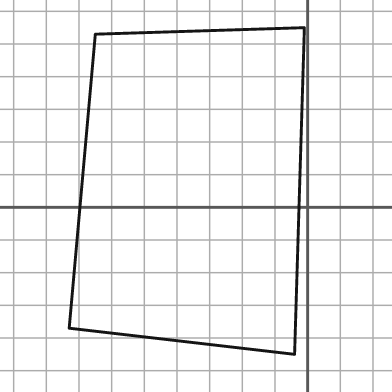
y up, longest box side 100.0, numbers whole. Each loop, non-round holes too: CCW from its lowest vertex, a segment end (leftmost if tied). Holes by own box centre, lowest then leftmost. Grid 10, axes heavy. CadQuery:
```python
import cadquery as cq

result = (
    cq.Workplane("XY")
    .moveTo(-4.0, -45.0)
    .lineTo(-1.0, 55.0)
    .lineTo(-65.0, 53.0)
    .lineTo(-73.0, -37.0)
    .close()
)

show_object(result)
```